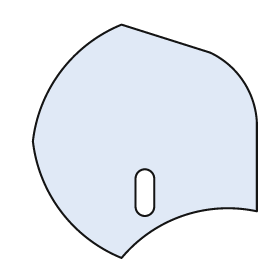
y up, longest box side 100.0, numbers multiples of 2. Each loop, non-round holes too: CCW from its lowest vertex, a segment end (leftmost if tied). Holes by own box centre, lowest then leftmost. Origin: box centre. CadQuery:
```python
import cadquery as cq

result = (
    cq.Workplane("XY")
    .moveTo(-10.0, -50.0)
    .threePointArc((16.0, -32.0), (48.0, -30.0))
    .lineTo(48.0, 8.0)
    .threePointArc((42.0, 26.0), (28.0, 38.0))
    .lineTo(-10.0, 50.0)
    .threePointArc((-36.0, 30.0), (-48.0, 0.0))
    .threePointArc((-36.0, -30.0), (-10.0, -50.0))
    .close()
    .moveTo(-4.0, -28.0)
    .threePointArc((0.0, -32.0), (4.0, -28.0))
    .lineTo(4.0, -16.0)
    .threePointArc((0.0, -12.0), (-4.0, -16.0))
    .close()
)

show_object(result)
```